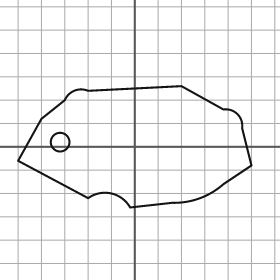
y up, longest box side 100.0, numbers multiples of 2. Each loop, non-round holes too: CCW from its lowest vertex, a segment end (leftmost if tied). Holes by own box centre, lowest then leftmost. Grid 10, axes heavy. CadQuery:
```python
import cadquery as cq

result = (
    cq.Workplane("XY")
    .moveTo(-2.0, -26.0)
    .lineTo(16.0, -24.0)
    .threePointArc((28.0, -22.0), (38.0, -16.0))
    .lineTo(50.0, -8.0)
    .lineTo(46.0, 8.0)
    .threePointArc((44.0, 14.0), (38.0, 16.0))
    .lineTo(20.0, 26.0)
    .lineTo(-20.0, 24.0)
    .threePointArc((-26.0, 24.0), (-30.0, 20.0))
    .lineTo(-40.0, 12.0)
    .lineTo(-50.0, -6.0)
    .lineTo(-20.0, -22.0)
    .threePointArc((-10.0, -20.0), (-2.0, -26.0))
    .close()
    .moveTo(-32.0, 2.0)
    .circle(4.0)
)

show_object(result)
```